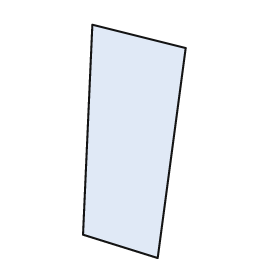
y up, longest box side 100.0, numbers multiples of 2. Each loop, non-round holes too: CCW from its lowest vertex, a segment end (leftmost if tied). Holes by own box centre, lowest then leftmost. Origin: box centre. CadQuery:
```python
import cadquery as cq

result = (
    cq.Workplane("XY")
    .moveTo(10.0, -50.0)
    .lineTo(22.0, 40.0)
    .lineTo(-18.0, 50.0)
    .lineTo(-22.0, -40.0)
    .close()
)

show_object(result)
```